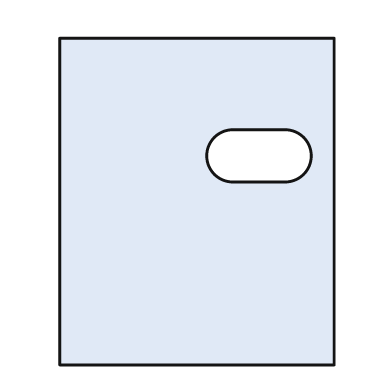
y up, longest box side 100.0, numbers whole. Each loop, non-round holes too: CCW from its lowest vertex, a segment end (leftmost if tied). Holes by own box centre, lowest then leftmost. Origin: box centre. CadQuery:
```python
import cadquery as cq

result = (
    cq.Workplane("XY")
    .moveTo(-42.0, -50.0)
    .lineTo(42.0, -50.0)
    .lineTo(42.0, 50.0)
    .lineTo(-42.0, 50.0)
    .close()
    .moveTo(11.0, 6.0)
    .lineTo(27.0, 6.0)
    .threePointArc((35.0, 14.0), (27.0, 22.0))
    .lineTo(11.0, 22.0)
    .threePointArc((3.0, 14.0), (11.0, 6.0))
    .close()
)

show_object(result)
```